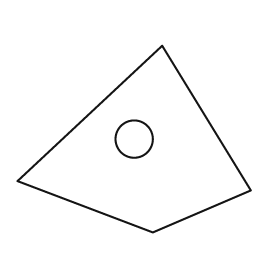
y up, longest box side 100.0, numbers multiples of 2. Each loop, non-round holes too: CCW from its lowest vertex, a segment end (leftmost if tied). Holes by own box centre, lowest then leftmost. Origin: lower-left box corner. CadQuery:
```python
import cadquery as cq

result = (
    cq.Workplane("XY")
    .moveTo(58.0, 0.0)
    .lineTo(100.0, 18.0)
    .lineTo(62.0, 80.0)
    .lineTo(0.0, 22.0)
    .close()
    .moveTo(50.0, 40.0)
    .circle(8.0)
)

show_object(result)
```